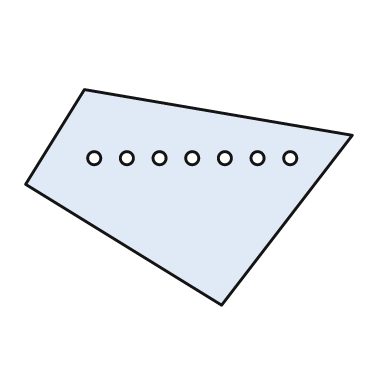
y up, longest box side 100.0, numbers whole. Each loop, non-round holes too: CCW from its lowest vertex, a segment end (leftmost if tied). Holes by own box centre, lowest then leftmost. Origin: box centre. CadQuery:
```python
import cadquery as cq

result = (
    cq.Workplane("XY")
    .moveTo(10.0, -33.0)
    .lineTo(50.0, 19.0)
    .lineTo(-32.0, 33.0)
    .lineTo(-50.0, 4.0)
    .close()
    .moveTo(-29.0, 12.0)
    .circle(2.0)
    .moveTo(-19.0, 12.0)
    .circle(2.0)
    .moveTo(-9.0, 12.0)
    .circle(2.0)
    .moveTo(1.0, 12.0)
    .circle(2.0)
    .moveTo(11.0, 12.0)
    .circle(2.0)
    .moveTo(21.0, 12.0)
    .circle(2.0)
    .moveTo(31.0, 12.0)
    .circle(2.0)
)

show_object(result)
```